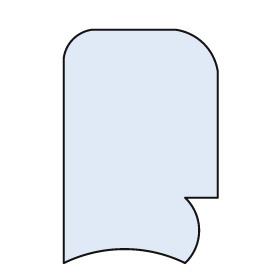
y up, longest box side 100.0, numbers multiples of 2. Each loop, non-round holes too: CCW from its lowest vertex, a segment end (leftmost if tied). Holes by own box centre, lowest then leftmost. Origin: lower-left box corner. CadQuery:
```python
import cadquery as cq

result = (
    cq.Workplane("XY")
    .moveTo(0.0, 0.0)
    .threePointArc((26.0, 6.0), (52.0, 0.0))
    .threePointArc((58.0, 14.0), (52.0, 28.0))
    .lineTo(66.0, 28.0)
    .lineTo(66.0, 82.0)
    .threePointArc((60.0, 94.0), (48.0, 100.0))
    .lineTo(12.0, 100.0)
    .threePointArc((4.0, 96.0), (0.0, 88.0))
    .close()
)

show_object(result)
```